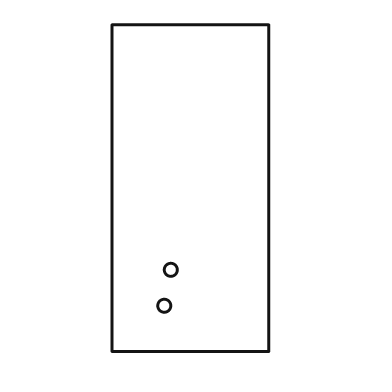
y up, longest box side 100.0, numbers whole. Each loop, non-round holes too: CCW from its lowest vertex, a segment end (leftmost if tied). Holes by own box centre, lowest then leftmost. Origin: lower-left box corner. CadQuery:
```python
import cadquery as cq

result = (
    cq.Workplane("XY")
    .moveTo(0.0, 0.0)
    .lineTo(48.0, 0.0)
    .lineTo(48.0, 100.0)
    .lineTo(0.0, 100.0)
    .close()
    .moveTo(16.0, 14.0)
    .circle(2.0)
    .moveTo(18.0, 25.0)
    .circle(2.0)
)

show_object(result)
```